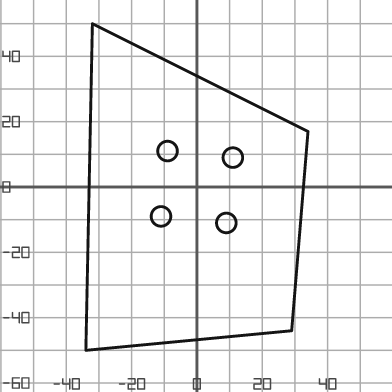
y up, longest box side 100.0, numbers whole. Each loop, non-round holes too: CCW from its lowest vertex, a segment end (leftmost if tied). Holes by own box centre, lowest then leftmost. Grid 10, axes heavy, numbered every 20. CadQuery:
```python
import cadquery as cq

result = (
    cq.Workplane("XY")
    .moveTo(-34.0, -50.0)
    .lineTo(29.0, -44.0)
    .lineTo(34.0, 17.0)
    .lineTo(-32.0, 50.0)
    .close()
    .moveTo(9.0, -11.0)
    .circle(3.0)
    .moveTo(-11.0, -9.0)
    .circle(3.0)
    .moveTo(11.0, 9.0)
    .circle(3.0)
    .moveTo(-9.0, 11.0)
    .circle(3.0)
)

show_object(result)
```